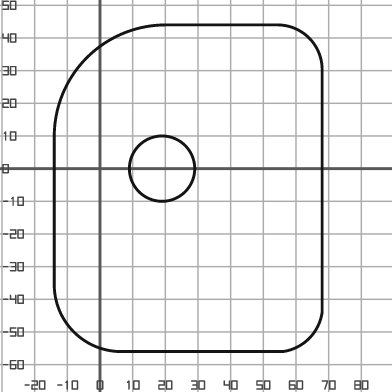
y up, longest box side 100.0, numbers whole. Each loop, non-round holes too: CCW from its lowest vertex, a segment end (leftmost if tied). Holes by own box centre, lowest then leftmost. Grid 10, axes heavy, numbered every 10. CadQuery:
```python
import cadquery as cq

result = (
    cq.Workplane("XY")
    .moveTo(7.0, -56.0)
    .lineTo(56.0, -56.0)
    .threePointArc((64.0, -52.0), (68.0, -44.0))
    .lineTo(68.0, 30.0)
    .threePointArc((64.0, 40.0), (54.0, 44.0))
    .lineTo(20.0, 44.0)
    .threePointArc((-4.0, 34.0), (-14.0, 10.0))
    .lineTo(-14.0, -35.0)
    .threePointArc((-8.0, -50.0), (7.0, -56.0))
    .close()
    .moveTo(19.0, 0.0)
    .circle(10.0)
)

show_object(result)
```